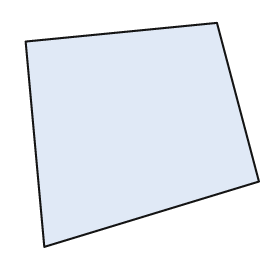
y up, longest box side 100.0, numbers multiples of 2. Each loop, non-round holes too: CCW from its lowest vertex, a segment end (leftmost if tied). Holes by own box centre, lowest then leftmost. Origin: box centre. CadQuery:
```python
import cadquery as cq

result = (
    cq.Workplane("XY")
    .moveTo(-42.0, -48.0)
    .lineTo(50.0, -20.0)
    .lineTo(32.0, 48.0)
    .lineTo(-50.0, 40.0)
    .close()
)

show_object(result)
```